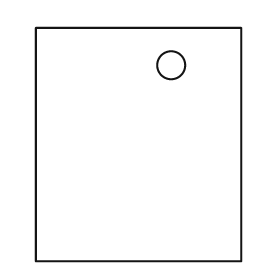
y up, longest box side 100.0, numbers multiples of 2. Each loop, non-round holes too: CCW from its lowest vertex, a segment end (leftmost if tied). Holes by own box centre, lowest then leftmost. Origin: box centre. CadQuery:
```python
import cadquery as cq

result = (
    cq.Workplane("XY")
    .moveTo(-44.0, -50.0)
    .lineTo(44.0, -50.0)
    .lineTo(44.0, 50.0)
    .lineTo(-44.0, 50.0)
    .close()
    .moveTo(14.0, 34.0)
    .circle(6.0)
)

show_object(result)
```